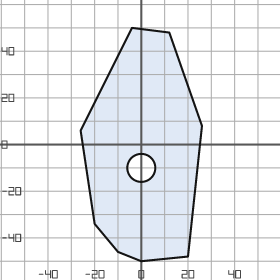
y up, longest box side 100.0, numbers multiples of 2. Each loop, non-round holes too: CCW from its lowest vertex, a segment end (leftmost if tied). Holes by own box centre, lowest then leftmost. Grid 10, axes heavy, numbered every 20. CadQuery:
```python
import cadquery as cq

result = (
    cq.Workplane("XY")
    .moveTo(0.0, -50.0)
    .lineTo(20.0, -48.0)
    .lineTo(26.0, 8.0)
    .lineTo(12.0, 48.0)
    .lineTo(-4.0, 50.0)
    .lineTo(-26.0, 6.0)
    .lineTo(-20.0, -34.0)
    .lineTo(-10.0, -46.0)
    .close()
    .moveTo(0.0, -10.0)
    .circle(6.0)
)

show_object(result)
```